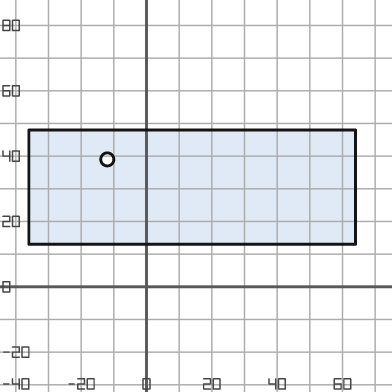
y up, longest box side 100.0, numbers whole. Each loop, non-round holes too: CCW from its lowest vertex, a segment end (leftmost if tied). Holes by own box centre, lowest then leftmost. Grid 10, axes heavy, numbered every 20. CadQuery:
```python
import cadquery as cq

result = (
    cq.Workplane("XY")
    .moveTo(-36.0, 13.0)
    .lineTo(64.0, 13.0)
    .lineTo(64.0, 48.0)
    .lineTo(-36.0, 48.0)
    .close()
    .moveTo(-12.0, 39.0)
    .circle(2.0)
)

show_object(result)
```